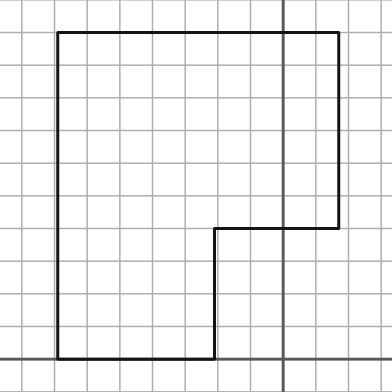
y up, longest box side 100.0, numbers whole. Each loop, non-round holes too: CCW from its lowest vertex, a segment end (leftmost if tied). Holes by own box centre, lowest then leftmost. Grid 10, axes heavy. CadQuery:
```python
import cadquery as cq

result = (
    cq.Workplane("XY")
    .moveTo(-69.0, 0.0)
    .lineTo(-21.0, 0.0)
    .lineTo(-21.0, 40.0)
    .lineTo(17.0, 40.0)
    .lineTo(17.0, 100.0)
    .lineTo(-69.0, 100.0)
    .close()
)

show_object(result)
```